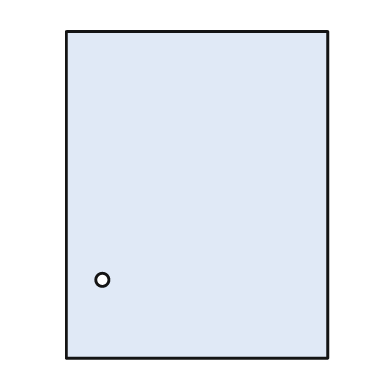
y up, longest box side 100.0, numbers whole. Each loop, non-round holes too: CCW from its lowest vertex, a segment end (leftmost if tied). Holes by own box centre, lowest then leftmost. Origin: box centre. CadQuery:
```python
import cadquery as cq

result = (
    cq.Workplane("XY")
    .moveTo(-40.0, -50.0)
    .lineTo(40.0, -50.0)
    .lineTo(40.0, 50.0)
    .lineTo(-40.0, 50.0)
    .close()
    .moveTo(-29.0, -26.0)
    .circle(2.0)
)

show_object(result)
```